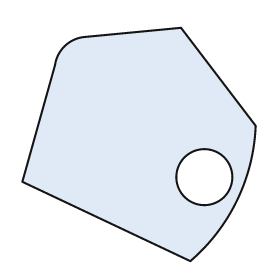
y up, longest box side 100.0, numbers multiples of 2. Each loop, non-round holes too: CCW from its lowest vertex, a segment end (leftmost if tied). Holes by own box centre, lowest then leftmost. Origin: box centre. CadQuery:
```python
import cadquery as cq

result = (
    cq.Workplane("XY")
    .moveTo(22.0, -50.0)
    .threePointArc((42.0, -24.0), (50.0, 8.0))
    .lineTo(18.0, 50.0)
    .lineTo(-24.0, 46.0)
    .threePointArc((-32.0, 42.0), (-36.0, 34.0))
    .lineTo(-50.0, -16.0)
    .close()
    .moveTo(28.0, -14.0)
    .circle(12.0)
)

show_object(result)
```